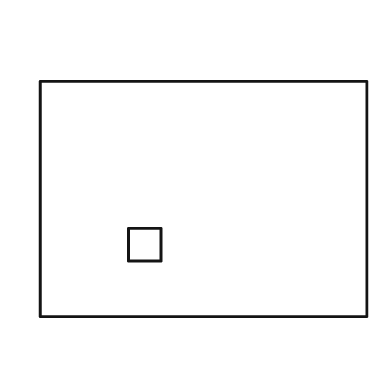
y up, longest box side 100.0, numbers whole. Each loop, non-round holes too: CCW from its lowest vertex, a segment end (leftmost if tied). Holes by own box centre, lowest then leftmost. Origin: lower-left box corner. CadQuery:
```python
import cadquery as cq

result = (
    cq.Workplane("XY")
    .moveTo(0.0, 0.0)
    .lineTo(100.0, 0.0)
    .lineTo(100.0, 72.0)
    .lineTo(0.0, 72.0)
    .close()
    .moveTo(27.0, 17.0)
    .lineTo(37.0, 17.0)
    .lineTo(37.0, 27.0)
    .lineTo(27.0, 27.0)
    .close()
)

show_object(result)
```